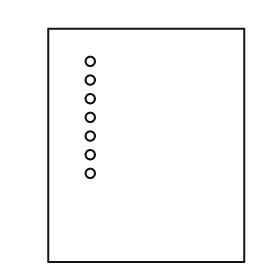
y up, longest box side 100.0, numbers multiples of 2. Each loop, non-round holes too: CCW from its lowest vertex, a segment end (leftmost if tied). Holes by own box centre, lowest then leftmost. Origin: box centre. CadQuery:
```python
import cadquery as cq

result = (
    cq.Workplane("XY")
    .moveTo(-42.0, -50.0)
    .lineTo(42.0, -50.0)
    .lineTo(42.0, 50.0)
    .lineTo(-42.0, 50.0)
    .close()
    .moveTo(-24.0, -12.0)
    .circle(2.0)
    .moveTo(-24.0, -4.0)
    .circle(2.0)
    .moveTo(-24.0, 4.0)
    .circle(2.0)
    .moveTo(-24.0, 12.0)
    .circle(2.0)
    .moveTo(-24.0, 20.0)
    .circle(2.0)
    .moveTo(-24.0, 28.0)
    .circle(2.0)
    .moveTo(-24.0, 36.0)
    .circle(2.0)
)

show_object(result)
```